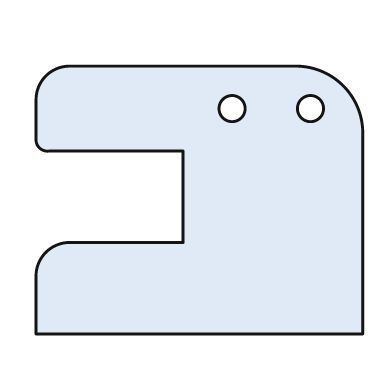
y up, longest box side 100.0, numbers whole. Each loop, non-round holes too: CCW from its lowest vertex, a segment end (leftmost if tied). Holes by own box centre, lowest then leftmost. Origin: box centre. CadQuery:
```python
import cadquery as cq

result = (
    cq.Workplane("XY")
    .moveTo(-50.0, -41.0)
    .lineTo(50.0, -41.0)
    .lineTo(50.0, 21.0)
    .threePointArc((44.0, 35.0), (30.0, 41.0))
    .lineTo(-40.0, 41.0)
    .threePointArc((-47.0, 38.0), (-50.0, 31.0))
    .lineTo(-50.0, 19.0)
    .threePointArc((-49.0, 16.0), (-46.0, 15.0))
    .lineTo(-5.0, 15.0)
    .lineTo(-5.0, -13.0)
    .lineTo(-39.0, -13.0)
    .threePointArc((-47.0, -16.0), (-50.0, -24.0))
    .close()
    .moveTo(10.0, 28.0)
    .circle(4.0)
    .moveTo(34.0, 28.0)
    .circle(4.0)
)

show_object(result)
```